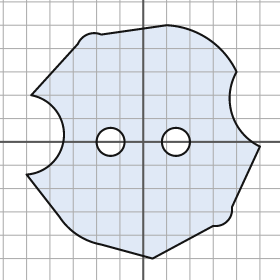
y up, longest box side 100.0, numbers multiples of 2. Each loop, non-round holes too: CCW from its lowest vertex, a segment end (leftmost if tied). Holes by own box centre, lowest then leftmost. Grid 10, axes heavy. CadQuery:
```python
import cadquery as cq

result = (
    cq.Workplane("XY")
    .moveTo(4.0, -50.0)
    .lineTo(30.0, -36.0)
    .threePointArc((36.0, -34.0), (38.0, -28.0))
    .lineTo(50.0, -2.0)
    .threePointArc((38.0, 12.0), (40.0, 30.0))
    .threePointArc((28.0, 44.0), (10.0, 50.0))
    .lineTo(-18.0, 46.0)
    .threePointArc((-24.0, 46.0), (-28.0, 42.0))
    .lineTo(-48.0, 20.0)
    .threePointArc((-34.0, 2.0), (-50.0, -14.0))
    .lineTo(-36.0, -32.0)
    .threePointArc((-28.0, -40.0), (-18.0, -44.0))
    .close()
    .moveTo(-14.0, 0.0)
    .circle(6.0)
    .moveTo(14.0, 0.0)
    .circle(6.0)
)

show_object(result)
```